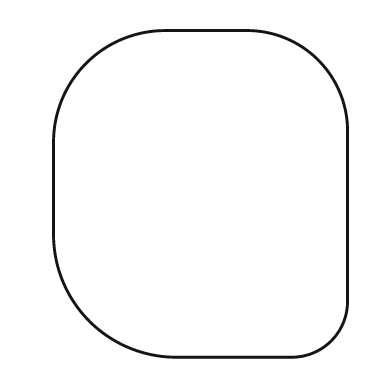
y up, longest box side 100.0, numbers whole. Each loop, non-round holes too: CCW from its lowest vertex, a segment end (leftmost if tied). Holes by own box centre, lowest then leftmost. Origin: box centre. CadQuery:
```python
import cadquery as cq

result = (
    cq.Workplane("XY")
    .moveTo(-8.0, -50.0)
    .lineTo(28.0, -50.0)
    .threePointArc((40.0, -45.0), (45.0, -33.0))
    .lineTo(45.0, 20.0)
    .threePointArc((36.0, 41.0), (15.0, 50.0))
    .lineTo(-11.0, 50.0)
    .threePointArc((-35.0, 40.0), (-45.0, 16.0))
    .lineTo(-45.0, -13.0)
    .threePointArc((-34.0, -39.0), (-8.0, -50.0))
    .close()
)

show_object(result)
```